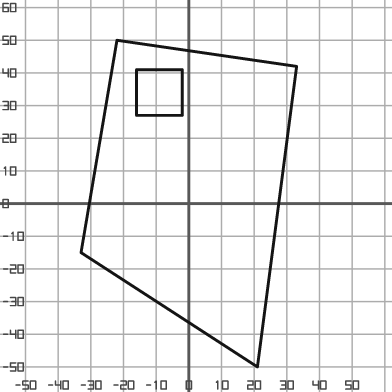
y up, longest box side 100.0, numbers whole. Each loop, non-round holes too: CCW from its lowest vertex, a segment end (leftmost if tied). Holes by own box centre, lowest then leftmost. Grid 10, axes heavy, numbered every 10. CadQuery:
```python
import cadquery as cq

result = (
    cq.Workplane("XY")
    .moveTo(21.0, -50.0)
    .lineTo(33.0, 42.0)
    .lineTo(-22.0, 50.0)
    .lineTo(-33.0, -15.0)
    .close()
    .moveTo(-16.0, 27.0)
    .lineTo(-2.0, 27.0)
    .lineTo(-2.0, 41.0)
    .lineTo(-16.0, 41.0)
    .close()
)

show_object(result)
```